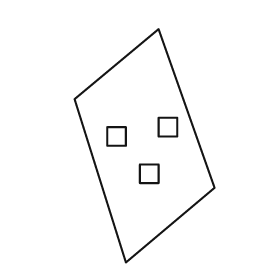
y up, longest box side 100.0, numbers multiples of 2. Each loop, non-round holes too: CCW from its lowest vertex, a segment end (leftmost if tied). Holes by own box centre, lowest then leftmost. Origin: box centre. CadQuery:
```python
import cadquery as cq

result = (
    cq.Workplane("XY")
    .moveTo(-8.0, -50.0)
    .lineTo(30.0, -18.0)
    .lineTo(6.0, 50.0)
    .lineTo(-30.0, 20.0)
    .close()
    .moveTo(-2.0, -16.0)
    .lineTo(6.0, -16.0)
    .lineTo(6.0, -8.0)
    .lineTo(-2.0, -8.0)
    .close()
    .moveTo(-16.0, 0.0)
    .lineTo(-8.0, 0.0)
    .lineTo(-8.0, 8.0)
    .lineTo(-16.0, 8.0)
    .close()
    .moveTo(6.0, 4.0)
    .lineTo(14.0, 4.0)
    .lineTo(14.0, 12.0)
    .lineTo(6.0, 12.0)
    .close()
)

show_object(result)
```